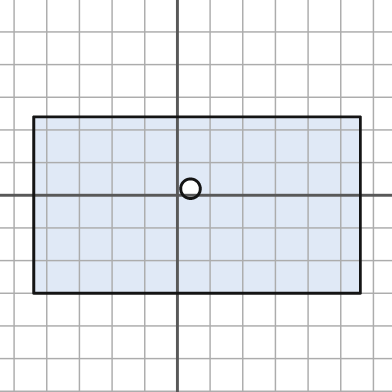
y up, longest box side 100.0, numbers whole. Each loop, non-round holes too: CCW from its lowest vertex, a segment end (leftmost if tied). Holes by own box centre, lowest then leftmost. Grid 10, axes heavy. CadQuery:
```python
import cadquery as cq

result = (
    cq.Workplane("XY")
    .moveTo(-44.0, -30.0)
    .lineTo(56.0, -30.0)
    .lineTo(56.0, 24.0)
    .lineTo(-44.0, 24.0)
    .close()
    .moveTo(4.0, 2.0)
    .circle(3.0)
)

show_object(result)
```